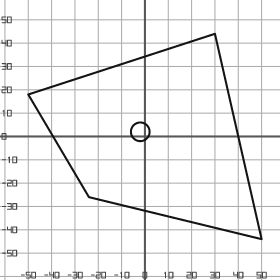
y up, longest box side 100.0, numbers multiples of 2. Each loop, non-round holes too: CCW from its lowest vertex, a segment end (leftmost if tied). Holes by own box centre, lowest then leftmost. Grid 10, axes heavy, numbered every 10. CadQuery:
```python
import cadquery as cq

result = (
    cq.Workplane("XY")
    .moveTo(50.0, -44.0)
    .lineTo(30.0, 44.0)
    .lineTo(-50.0, 18.0)
    .lineTo(-24.0, -26.0)
    .close()
    .moveTo(-2.0, 2.0)
    .circle(4.0)
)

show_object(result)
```